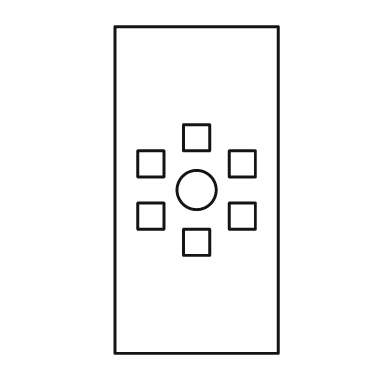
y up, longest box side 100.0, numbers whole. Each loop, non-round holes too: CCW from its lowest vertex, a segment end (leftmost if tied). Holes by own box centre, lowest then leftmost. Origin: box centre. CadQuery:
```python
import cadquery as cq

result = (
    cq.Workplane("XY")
    .moveTo(-25.0, -50.0)
    .lineTo(25.0, -50.0)
    .lineTo(25.0, 50.0)
    .lineTo(-25.0, 50.0)
    .close()
    .moveTo(-4.0, -20.0)
    .lineTo(4.0, -20.0)
    .lineTo(4.0, -12.0)
    .lineTo(-4.0, -12.0)
    .close()
    .moveTo(-18.0, -12.0)
    .lineTo(-10.0, -12.0)
    .lineTo(-10.0, -4.0)
    .lineTo(-18.0, -4.0)
    .close()
    .moveTo(10.0, -12.0)
    .lineTo(18.0, -12.0)
    .lineTo(18.0, -4.0)
    .lineTo(10.0, -4.0)
    .close()
    .moveTo(0.0, 0.0)
    .circle(6.0)
    .moveTo(-18.0, 4.0)
    .lineTo(-10.0, 4.0)
    .lineTo(-10.0, 12.0)
    .lineTo(-18.0, 12.0)
    .close()
    .moveTo(10.0, 4.0)
    .lineTo(18.0, 4.0)
    .lineTo(18.0, 12.0)
    .lineTo(10.0, 12.0)
    .close()
    .moveTo(-4.0, 12.0)
    .lineTo(4.0, 12.0)
    .lineTo(4.0, 20.0)
    .lineTo(-4.0, 20.0)
    .close()
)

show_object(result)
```